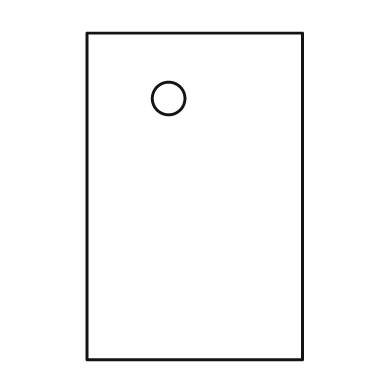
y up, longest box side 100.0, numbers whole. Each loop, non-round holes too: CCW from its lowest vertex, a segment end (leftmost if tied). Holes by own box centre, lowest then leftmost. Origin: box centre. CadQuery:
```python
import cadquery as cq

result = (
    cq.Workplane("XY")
    .moveTo(-33.0, -50.0)
    .lineTo(33.0, -50.0)
    .lineTo(33.0, 50.0)
    .lineTo(-33.0, 50.0)
    .close()
    .moveTo(-8.0, 30.0)
    .circle(5.0)
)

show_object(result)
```